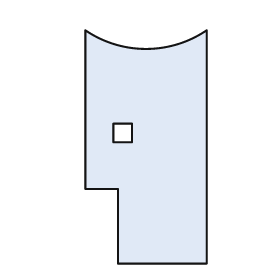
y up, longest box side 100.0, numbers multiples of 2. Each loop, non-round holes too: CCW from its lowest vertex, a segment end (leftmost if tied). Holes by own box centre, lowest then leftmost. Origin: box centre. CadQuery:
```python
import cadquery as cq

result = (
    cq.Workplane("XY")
    .moveTo(-12.0, -50.0)
    .lineTo(26.0, -50.0)
    .lineTo(26.0, 50.0)
    .threePointArc((0.0, 42.0), (-26.0, 50.0))
    .lineTo(-26.0, -18.0)
    .lineTo(-12.0, -18.0)
    .close()
    .moveTo(-14.0, 2.0)
    .lineTo(-6.0, 2.0)
    .lineTo(-6.0, 10.0)
    .lineTo(-14.0, 10.0)
    .close()
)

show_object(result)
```